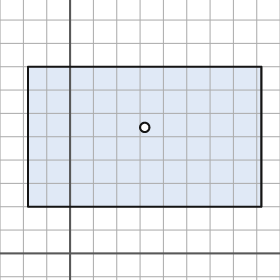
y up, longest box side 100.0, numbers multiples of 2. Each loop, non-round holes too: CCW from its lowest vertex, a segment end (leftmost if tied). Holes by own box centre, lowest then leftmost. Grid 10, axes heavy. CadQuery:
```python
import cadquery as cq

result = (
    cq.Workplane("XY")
    .moveTo(-18.0, 20.0)
    .lineTo(82.0, 20.0)
    .lineTo(82.0, 80.0)
    .lineTo(-18.0, 80.0)
    .close()
    .moveTo(32.0, 54.0)
    .circle(2.0)
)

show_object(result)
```